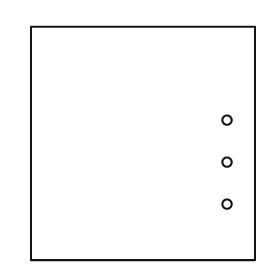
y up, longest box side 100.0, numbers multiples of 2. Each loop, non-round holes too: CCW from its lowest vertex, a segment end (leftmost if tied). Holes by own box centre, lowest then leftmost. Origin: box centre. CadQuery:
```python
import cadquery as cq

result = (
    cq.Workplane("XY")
    .moveTo(-48.0, -50.0)
    .lineTo(48.0, -50.0)
    .lineTo(48.0, 50.0)
    .lineTo(-48.0, 50.0)
    .close()
    .moveTo(36.0, -26.0)
    .circle(2.0)
    .moveTo(36.0, -8.0)
    .circle(2.0)
    .moveTo(36.0, 10.0)
    .circle(2.0)
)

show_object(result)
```